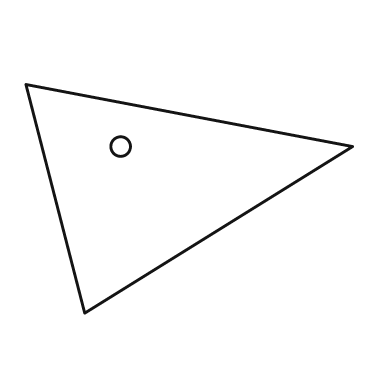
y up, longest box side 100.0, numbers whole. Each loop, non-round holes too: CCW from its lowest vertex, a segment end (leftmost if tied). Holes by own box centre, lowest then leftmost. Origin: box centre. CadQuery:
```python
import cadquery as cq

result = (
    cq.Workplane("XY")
    .moveTo(-32.0, -35.0)
    .lineTo(50.0, 16.0)
    .lineTo(-50.0, 35.0)
    .close()
    .moveTo(-21.0, 16.0)
    .circle(3.0)
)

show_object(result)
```